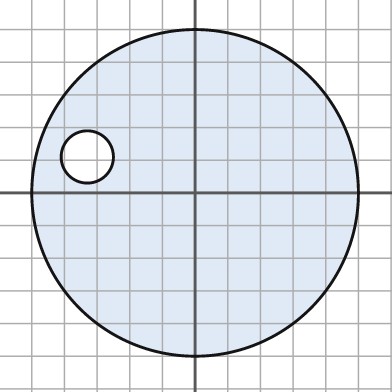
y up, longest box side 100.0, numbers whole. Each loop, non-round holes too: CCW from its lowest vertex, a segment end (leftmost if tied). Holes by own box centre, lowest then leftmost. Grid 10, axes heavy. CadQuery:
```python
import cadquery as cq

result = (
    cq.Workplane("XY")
    .moveTo(0.0, 0.0)
    .circle(50.0)
    .moveTo(-33.0, 11.0)
    .circle(8.0)
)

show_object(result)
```